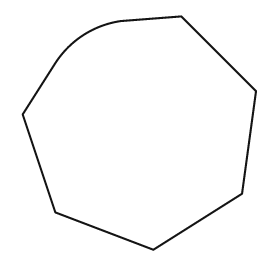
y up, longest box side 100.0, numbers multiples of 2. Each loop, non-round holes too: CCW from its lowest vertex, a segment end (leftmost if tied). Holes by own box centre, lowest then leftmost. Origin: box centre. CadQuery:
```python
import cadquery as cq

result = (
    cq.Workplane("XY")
    .moveTo(6.0, -50.0)
    .lineTo(44.0, -26.0)
    .lineTo(50.0, 18.0)
    .lineTo(18.0, 50.0)
    .lineTo(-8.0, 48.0)
    .threePointArc((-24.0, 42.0), (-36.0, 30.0))
    .lineTo(-50.0, 8.0)
    .lineTo(-36.0, -34.0)
    .close()
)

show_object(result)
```